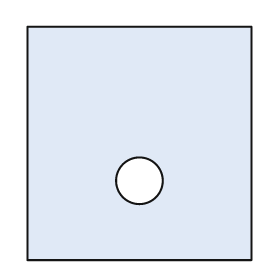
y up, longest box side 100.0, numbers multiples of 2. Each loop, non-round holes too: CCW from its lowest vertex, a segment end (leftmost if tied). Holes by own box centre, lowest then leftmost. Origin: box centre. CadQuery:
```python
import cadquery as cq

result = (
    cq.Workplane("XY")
    .moveTo(-48.0, -50.0)
    .lineTo(48.0, -50.0)
    .lineTo(48.0, 50.0)
    .lineTo(-48.0, 50.0)
    .close()
    .moveTo(0.0, -16.0)
    .circle(10.0)
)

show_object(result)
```